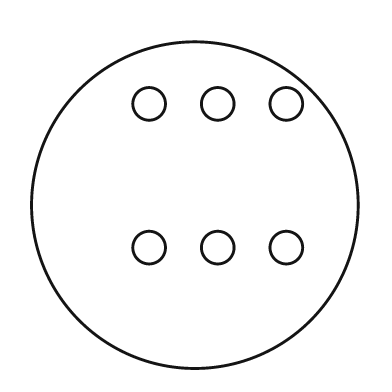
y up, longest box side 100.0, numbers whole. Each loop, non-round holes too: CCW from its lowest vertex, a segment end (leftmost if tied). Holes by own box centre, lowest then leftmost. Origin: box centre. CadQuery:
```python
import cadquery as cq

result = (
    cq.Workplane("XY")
    .moveTo(0.0, 0.0)
    .circle(50.0)
    .moveTo(-14.0, -13.0)
    .circle(5.0)
    .moveTo(7.0, -13.0)
    .circle(5.0)
    .moveTo(28.0, -13.0)
    .circle(5.0)
    .moveTo(-14.0, 31.0)
    .circle(5.0)
    .moveTo(7.0, 31.0)
    .circle(5.0)
    .moveTo(28.0, 31.0)
    .circle(5.0)
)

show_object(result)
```